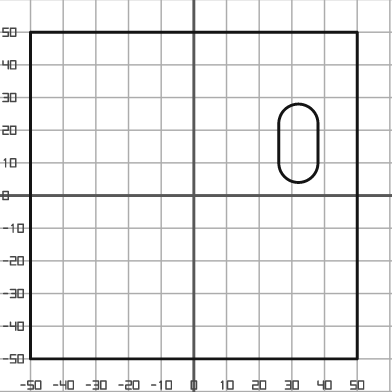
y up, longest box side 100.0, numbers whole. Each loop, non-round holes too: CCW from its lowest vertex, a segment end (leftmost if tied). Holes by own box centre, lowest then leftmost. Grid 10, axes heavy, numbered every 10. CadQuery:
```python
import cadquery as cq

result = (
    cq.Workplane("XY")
    .moveTo(-50.0, -50.0)
    .lineTo(50.0, -50.0)
    .lineTo(50.0, 50.0)
    .lineTo(-50.0, 50.0)
    .close()
    .moveTo(26.0, 10.0)
    .threePointArc((32.0, 4.0), (38.0, 10.0))
    .lineTo(38.0, 22.0)
    .threePointArc((32.0, 28.0), (26.0, 22.0))
    .close()
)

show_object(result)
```